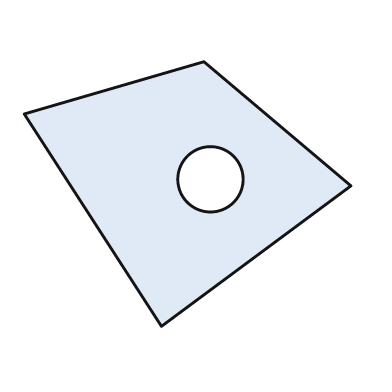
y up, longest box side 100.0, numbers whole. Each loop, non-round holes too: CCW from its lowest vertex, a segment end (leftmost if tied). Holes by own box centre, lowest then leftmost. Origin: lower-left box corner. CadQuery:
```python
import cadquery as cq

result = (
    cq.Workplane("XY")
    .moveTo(42.0, 0.0)
    .lineTo(100.0, 43.0)
    .lineTo(55.0, 81.0)
    .lineTo(0.0, 65.0)
    .close()
    .moveTo(57.0, 45.0)
    .circle(10.0)
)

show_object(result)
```